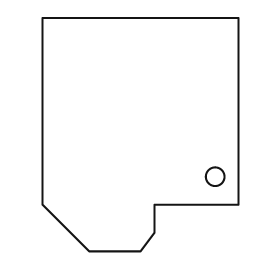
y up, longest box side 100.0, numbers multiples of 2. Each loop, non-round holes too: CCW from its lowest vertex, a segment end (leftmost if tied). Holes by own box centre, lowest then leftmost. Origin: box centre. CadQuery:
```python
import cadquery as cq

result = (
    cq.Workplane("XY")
    .moveTo(-22.0, -50.0)
    .lineTo(0.0, -50.0)
    .lineTo(6.0, -42.0)
    .lineTo(6.0, -30.0)
    .lineTo(42.0, -30.0)
    .lineTo(42.0, 50.0)
    .lineTo(-42.0, 50.0)
    .lineTo(-42.0, -30.0)
    .close()
    .moveTo(32.0, -18.0)
    .circle(4.0)
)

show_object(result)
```